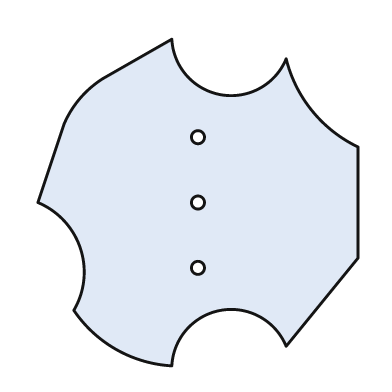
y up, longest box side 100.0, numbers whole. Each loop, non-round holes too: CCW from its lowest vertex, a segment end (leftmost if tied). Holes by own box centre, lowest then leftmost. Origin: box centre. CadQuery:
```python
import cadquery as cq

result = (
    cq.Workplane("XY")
    .moveTo(-8.0, -50.0)
    .threePointArc((7.0, -33.0), (27.0, -44.0))
    .lineTo(49.0, -17.0)
    .lineTo(49.0, 17.0)
    .threePointArc((35.0, 28.0), (27.0, 44.0))
    .threePointArc((7.0, 33.0), (-8.0, 50.0))
    .lineTo(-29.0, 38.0)
    .threePointArc((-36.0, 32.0), (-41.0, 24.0))
    .lineTo(-49.0, 0.0)
    .threePointArc((-36.0, -14.0), (-38.0, -33.0))
    .threePointArc((-25.0, -45.0), (-8.0, -50.0))
    .close()
    .moveTo(0.0, -20.0)
    .circle(2.0)
    .moveTo(0.0, 0.0)
    .circle(2.0)
    .moveTo(0.0, 20.0)
    .circle(2.0)
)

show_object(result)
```